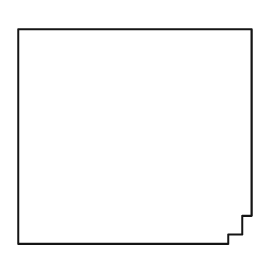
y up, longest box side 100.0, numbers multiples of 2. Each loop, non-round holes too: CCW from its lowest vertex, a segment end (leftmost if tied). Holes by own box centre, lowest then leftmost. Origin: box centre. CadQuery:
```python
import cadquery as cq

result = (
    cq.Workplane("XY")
    .moveTo(-50.0, -46.0)
    .lineTo(40.0, -46.0)
    .lineTo(40.0, -42.0)
    .lineTo(46.0, -42.0)
    .lineTo(46.0, -34.0)
    .lineTo(50.0, -34.0)
    .lineTo(50.0, 46.0)
    .lineTo(-50.0, 46.0)
    .close()
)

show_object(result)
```